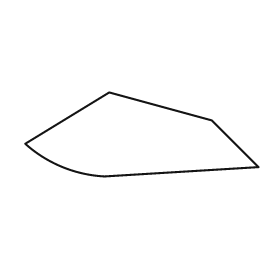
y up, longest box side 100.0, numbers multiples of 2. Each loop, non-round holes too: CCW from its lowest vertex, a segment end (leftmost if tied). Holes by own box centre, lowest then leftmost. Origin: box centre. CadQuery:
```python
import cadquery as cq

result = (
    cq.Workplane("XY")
    .moveTo(-16.0, -18.0)
    .lineTo(50.0, -14.0)
    .lineTo(30.0, 6.0)
    .lineTo(-14.0, 18.0)
    .lineTo(-50.0, -4.0)
    .threePointArc((-34.0, -14.0), (-16.0, -18.0))
    .close()
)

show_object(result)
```